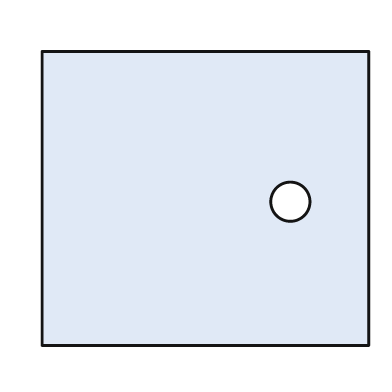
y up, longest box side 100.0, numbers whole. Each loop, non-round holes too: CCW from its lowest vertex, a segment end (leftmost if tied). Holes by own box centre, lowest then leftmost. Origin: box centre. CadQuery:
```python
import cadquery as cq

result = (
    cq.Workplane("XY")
    .moveTo(-50.0, -45.0)
    .lineTo(50.0, -45.0)
    .lineTo(50.0, 45.0)
    .lineTo(-50.0, 45.0)
    .close()
    .moveTo(26.0, -1.0)
    .circle(6.0)
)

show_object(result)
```